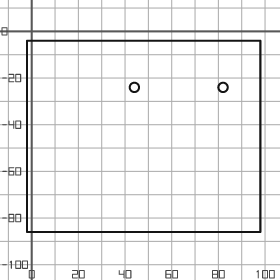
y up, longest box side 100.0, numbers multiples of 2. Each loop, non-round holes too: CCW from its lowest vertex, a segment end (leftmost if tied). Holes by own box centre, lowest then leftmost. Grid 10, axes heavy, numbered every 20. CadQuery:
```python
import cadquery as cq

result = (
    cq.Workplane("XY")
    .moveTo(-2.0, -86.0)
    .lineTo(98.0, -86.0)
    .lineTo(98.0, -4.0)
    .lineTo(-2.0, -4.0)
    .close()
    .moveTo(44.0, -24.0)
    .circle(2.0)
    .moveTo(82.0, -24.0)
    .circle(2.0)
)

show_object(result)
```